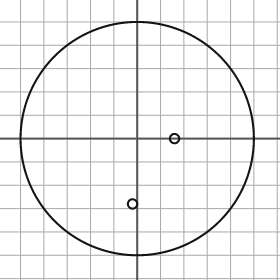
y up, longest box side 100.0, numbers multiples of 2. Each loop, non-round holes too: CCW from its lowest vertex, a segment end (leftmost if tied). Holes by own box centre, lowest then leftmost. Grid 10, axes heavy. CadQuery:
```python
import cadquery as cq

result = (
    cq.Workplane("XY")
    .moveTo(0.0, 0.0)
    .circle(50.0)
    .moveTo(-2.0, -28.0)
    .circle(2.0)
    .moveTo(16.0, 0.0)
    .circle(2.0)
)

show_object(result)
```